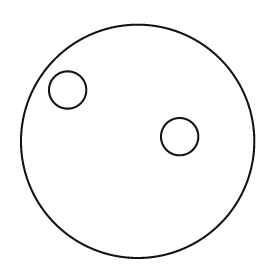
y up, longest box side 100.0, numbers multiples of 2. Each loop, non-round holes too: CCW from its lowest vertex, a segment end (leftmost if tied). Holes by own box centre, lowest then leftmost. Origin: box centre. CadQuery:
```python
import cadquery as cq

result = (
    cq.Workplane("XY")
    .moveTo(0.0, 0.0)
    .circle(50.0)
    .moveTo(18.0, 2.0)
    .circle(8.0)
    .moveTo(-30.0, 22.0)
    .circle(8.0)
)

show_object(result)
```